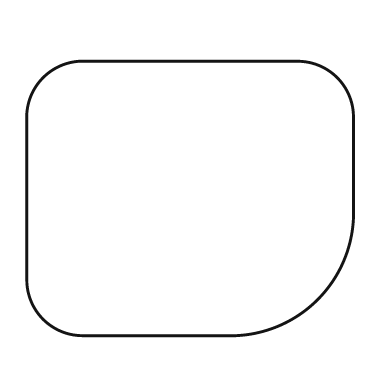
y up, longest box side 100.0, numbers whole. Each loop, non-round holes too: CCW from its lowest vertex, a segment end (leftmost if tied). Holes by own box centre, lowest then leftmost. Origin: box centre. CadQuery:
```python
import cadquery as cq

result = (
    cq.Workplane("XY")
    .moveTo(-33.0, -42.0)
    .lineTo(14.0, -42.0)
    .threePointArc((39.0, -31.0), (50.0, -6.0))
    .lineTo(50.0, 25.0)
    .threePointArc((45.0, 37.0), (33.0, 42.0))
    .lineTo(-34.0, 42.0)
    .threePointArc((-45.0, 37.0), (-50.0, 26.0))
    .lineTo(-50.0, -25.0)
    .threePointArc((-45.0, -37.0), (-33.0, -42.0))
    .close()
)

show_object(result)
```